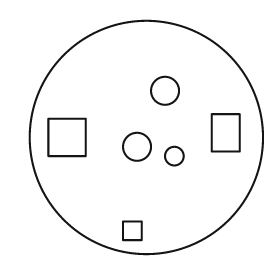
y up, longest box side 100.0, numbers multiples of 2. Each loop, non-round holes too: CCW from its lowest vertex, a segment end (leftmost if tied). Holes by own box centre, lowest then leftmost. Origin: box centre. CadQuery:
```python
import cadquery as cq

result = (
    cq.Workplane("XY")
    .moveTo(0.0, 0.0)
    .circle(50.0)
    .moveTo(-10.0, -44.0)
    .lineTo(-2.0, -44.0)
    .lineTo(-2.0, -36.0)
    .lineTo(-10.0, -36.0)
    .close()
    .moveTo(12.0, -8.0)
    .circle(4.0)
    .moveTo(-4.0, -4.0)
    .circle(6.0)
    .moveTo(-42.0, -8.0)
    .lineTo(-26.0, -8.0)
    .lineTo(-26.0, 8.0)
    .lineTo(-42.0, 8.0)
    .close()
    .moveTo(28.0, -6.0)
    .lineTo(40.0, -6.0)
    .lineTo(40.0, 10.0)
    .lineTo(28.0, 10.0)
    .close()
    .moveTo(8.0, 20.0)
    .circle(6.0)
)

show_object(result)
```